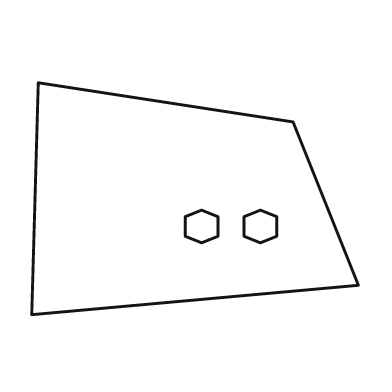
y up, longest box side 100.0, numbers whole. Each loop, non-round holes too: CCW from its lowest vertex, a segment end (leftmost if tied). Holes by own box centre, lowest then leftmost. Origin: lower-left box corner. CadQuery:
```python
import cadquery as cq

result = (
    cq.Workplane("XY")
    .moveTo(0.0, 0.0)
    .lineTo(100.0, 9.0)
    .lineTo(80.0, 59.0)
    .lineTo(2.0, 71.0)
    .close()
    .moveTo(52.0, 22.0)
    .lineTo(57.0, 24.0)
    .lineTo(57.0, 30.0)
    .lineTo(52.0, 32.0)
    .lineTo(47.0, 30.0)
    .lineTo(47.0, 24.0)
    .close()
    .moveTo(70.0, 22.0)
    .lineTo(75.0, 24.0)
    .lineTo(75.0, 30.0)
    .lineTo(70.0, 32.0)
    .lineTo(65.0, 30.0)
    .lineTo(65.0, 24.0)
    .close()
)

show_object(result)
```